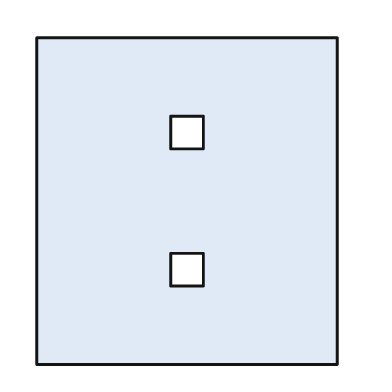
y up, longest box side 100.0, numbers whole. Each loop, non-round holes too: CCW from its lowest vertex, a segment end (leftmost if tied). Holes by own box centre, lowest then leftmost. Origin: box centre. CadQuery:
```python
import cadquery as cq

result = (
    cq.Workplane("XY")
    .moveTo(-46.0, -50.0)
    .lineTo(46.0, -50.0)
    .lineTo(46.0, 50.0)
    .lineTo(-46.0, 50.0)
    .close()
    .moveTo(-5.0, -26.0)
    .lineTo(5.0, -26.0)
    .lineTo(5.0, -16.0)
    .lineTo(-5.0, -16.0)
    .close()
    .moveTo(-5.0, 16.0)
    .lineTo(5.0, 16.0)
    .lineTo(5.0, 26.0)
    .lineTo(-5.0, 26.0)
    .close()
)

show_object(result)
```